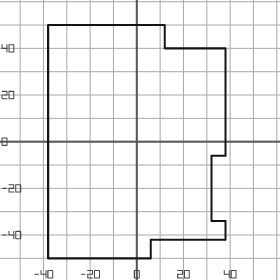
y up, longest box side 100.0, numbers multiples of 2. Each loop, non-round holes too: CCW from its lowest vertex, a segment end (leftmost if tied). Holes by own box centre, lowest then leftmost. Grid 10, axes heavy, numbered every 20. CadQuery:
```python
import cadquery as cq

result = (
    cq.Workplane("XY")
    .moveTo(-38.0, -50.0)
    .lineTo(6.0, -50.0)
    .lineTo(6.0, -42.0)
    .lineTo(38.0, -42.0)
    .lineTo(38.0, -34.0)
    .lineTo(32.0, -34.0)
    .lineTo(32.0, -6.0)
    .lineTo(38.0, -6.0)
    .lineTo(38.0, 40.0)
    .lineTo(12.0, 40.0)
    .lineTo(12.0, 50.0)
    .lineTo(-38.0, 50.0)
    .close()
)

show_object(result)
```